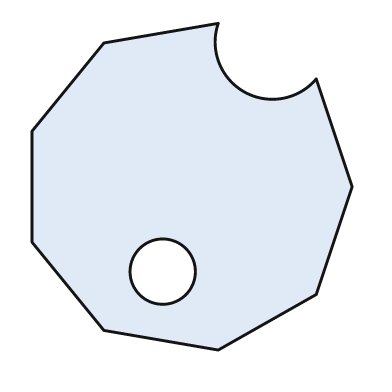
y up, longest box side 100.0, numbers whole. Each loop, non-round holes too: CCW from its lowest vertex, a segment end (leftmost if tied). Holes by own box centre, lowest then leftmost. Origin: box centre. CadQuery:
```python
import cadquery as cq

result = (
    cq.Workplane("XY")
    .moveTo(8.0, -50.0)
    .lineTo(38.0, -33.0)
    .lineTo(49.0, 0.0)
    .lineTo(38.0, 33.0)
    .threePointArc((16.0, 29.0), (8.0, 50.0))
    .lineTo(-27.0, 44.0)
    .lineTo(-49.0, 17.0)
    .lineTo(-49.0, -17.0)
    .lineTo(-27.0, -44.0)
    .close()
    .moveTo(-9.0, -26.0)
    .circle(10.0)
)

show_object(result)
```